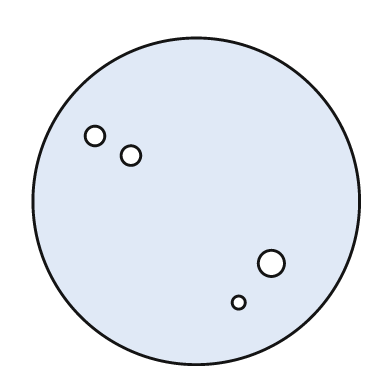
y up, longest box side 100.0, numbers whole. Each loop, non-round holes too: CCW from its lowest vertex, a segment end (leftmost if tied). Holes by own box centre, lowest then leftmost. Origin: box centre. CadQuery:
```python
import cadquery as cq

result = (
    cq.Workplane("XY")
    .moveTo(0.0, 0.0)
    .circle(50.0)
    .moveTo(13.0, -31.0)
    .circle(2.0)
    .moveTo(23.0, -19.0)
    .circle(4.0)
    .moveTo(-20.0, 14.0)
    .circle(3.0)
    .moveTo(-31.0, 20.0)
    .circle(3.0)
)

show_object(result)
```